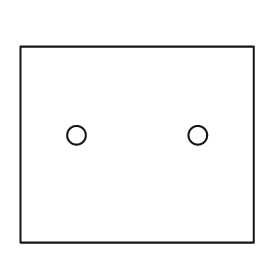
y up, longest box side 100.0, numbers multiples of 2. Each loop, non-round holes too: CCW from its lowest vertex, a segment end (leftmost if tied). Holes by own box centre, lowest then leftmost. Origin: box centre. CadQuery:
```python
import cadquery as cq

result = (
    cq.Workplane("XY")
    .moveTo(-50.0, -42.0)
    .lineTo(50.0, -42.0)
    .lineTo(50.0, 42.0)
    .lineTo(-50.0, 42.0)
    .close()
    .moveTo(-26.0, 4.0)
    .circle(4.0)
    .moveTo(26.0, 4.0)
    .circle(4.0)
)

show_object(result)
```